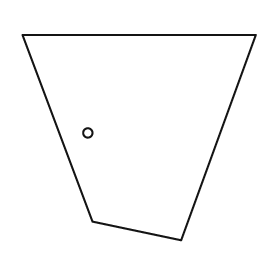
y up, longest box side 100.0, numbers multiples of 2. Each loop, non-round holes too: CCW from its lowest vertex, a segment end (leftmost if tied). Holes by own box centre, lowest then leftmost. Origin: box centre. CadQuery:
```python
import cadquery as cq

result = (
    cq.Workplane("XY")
    .moveTo(18.0, -44.0)
    .lineTo(50.0, 44.0)
    .lineTo(-50.0, 44.0)
    .lineTo(-20.0, -36.0)
    .close()
    .moveTo(-22.0, 2.0)
    .circle(2.0)
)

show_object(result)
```